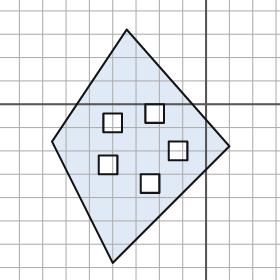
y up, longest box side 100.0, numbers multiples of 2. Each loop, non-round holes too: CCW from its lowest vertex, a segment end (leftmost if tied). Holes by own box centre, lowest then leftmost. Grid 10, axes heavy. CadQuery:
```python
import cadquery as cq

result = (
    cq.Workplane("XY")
    .moveTo(-40.0, -68.0)
    .lineTo(10.0, -18.0)
    .lineTo(-34.0, 32.0)
    .lineTo(-66.0, -16.0)
    .close()
    .moveTo(-28.0, -38.0)
    .lineTo(-20.0, -38.0)
    .lineTo(-20.0, -30.0)
    .lineTo(-28.0, -30.0)
    .close()
    .moveTo(-46.0, -30.0)
    .lineTo(-38.0, -30.0)
    .lineTo(-38.0, -22.0)
    .lineTo(-46.0, -22.0)
    .close()
    .moveTo(-16.0, -24.0)
    .lineTo(-8.0, -24.0)
    .lineTo(-8.0, -16.0)
    .lineTo(-16.0, -16.0)
    .close()
    .moveTo(-44.0, -12.0)
    .lineTo(-36.0, -12.0)
    .lineTo(-36.0, -4.0)
    .lineTo(-44.0, -4.0)
    .close()
    .moveTo(-26.0, -8.0)
    .lineTo(-18.0, -8.0)
    .lineTo(-18.0, 0.0)
    .lineTo(-26.0, 0.0)
    .close()
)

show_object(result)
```